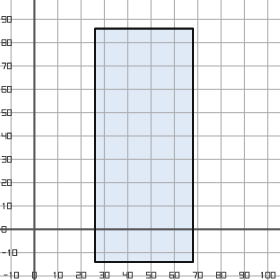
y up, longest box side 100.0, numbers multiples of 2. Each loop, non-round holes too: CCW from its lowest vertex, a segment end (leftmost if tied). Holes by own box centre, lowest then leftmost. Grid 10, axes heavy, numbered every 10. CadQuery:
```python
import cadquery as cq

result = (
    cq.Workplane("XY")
    .moveTo(26.0, -14.0)
    .lineTo(68.0, -14.0)
    .lineTo(68.0, 86.0)
    .lineTo(26.0, 86.0)
    .close()
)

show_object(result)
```